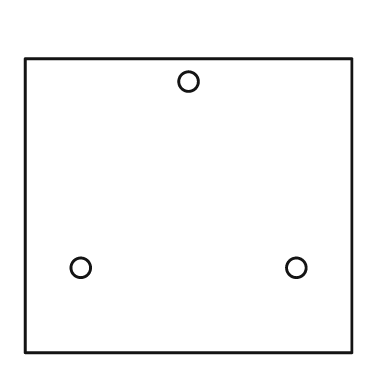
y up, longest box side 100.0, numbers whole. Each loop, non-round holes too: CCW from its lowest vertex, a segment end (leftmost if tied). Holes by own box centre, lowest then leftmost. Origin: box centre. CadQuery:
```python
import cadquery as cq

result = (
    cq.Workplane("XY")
    .moveTo(-50.0, -45.0)
    .lineTo(50.0, -45.0)
    .lineTo(50.0, 45.0)
    .lineTo(-50.0, 45.0)
    .close()
    .moveTo(-33.0, -19.0)
    .circle(3.0)
    .moveTo(33.0, -19.0)
    .circle(3.0)
    .moveTo(0.0, 38.0)
    .circle(3.0)
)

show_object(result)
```